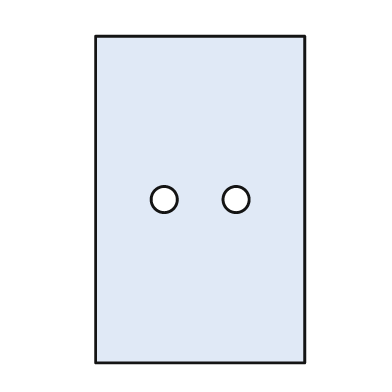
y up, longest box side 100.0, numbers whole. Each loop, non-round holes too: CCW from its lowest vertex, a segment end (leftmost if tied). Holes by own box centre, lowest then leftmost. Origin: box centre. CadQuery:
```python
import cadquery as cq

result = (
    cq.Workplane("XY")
    .moveTo(-32.0, -50.0)
    .lineTo(32.0, -50.0)
    .lineTo(32.0, 50.0)
    .lineTo(-32.0, 50.0)
    .close()
    .moveTo(-11.0, 0.0)
    .circle(4.0)
    .moveTo(11.0, 0.0)
    .circle(4.0)
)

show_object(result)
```